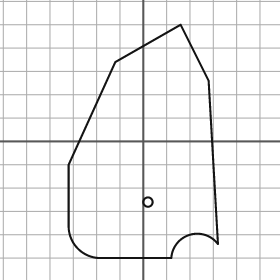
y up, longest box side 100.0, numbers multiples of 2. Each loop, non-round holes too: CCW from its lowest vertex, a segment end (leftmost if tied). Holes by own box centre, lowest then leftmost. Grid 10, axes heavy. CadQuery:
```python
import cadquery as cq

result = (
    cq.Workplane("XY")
    .moveTo(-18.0, -50.0)
    .lineTo(12.0, -50.0)
    .threePointArc((20.0, -40.0), (32.0, -44.0))
    .lineTo(28.0, 26.0)
    .lineTo(16.0, 50.0)
    .lineTo(-12.0, 34.0)
    .lineTo(-32.0, -10.0)
    .lineTo(-32.0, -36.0)
    .threePointArc((-28.0, -46.0), (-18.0, -50.0))
    .close()
    .moveTo(2.0, -26.0)
    .circle(2.0)
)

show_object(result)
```